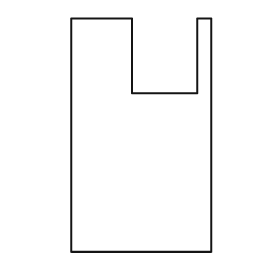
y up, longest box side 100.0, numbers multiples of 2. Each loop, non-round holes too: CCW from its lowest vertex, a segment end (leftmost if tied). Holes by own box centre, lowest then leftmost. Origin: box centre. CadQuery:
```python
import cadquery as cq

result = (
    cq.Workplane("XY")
    .moveTo(-30.0, -50.0)
    .lineTo(30.0, -50.0)
    .lineTo(30.0, 50.0)
    .lineTo(24.0, 50.0)
    .lineTo(24.0, 18.0)
    .lineTo(-4.0, 18.0)
    .lineTo(-4.0, 50.0)
    .lineTo(-30.0, 50.0)
    .close()
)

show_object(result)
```